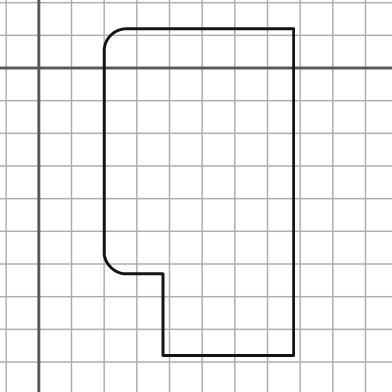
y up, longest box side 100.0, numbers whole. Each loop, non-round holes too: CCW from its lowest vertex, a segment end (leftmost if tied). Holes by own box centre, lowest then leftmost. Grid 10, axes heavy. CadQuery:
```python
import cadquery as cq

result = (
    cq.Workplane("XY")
    .moveTo(38.0, -88.0)
    .lineTo(78.0, -88.0)
    .lineTo(78.0, 12.0)
    .lineTo(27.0, 12.0)
    .threePointArc((22.0, 10.0), (20.0, 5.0))
    .lineTo(20.0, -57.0)
    .threePointArc((22.0, -61.0), (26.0, -63.0))
    .lineTo(38.0, -63.0)
    .close()
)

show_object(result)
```